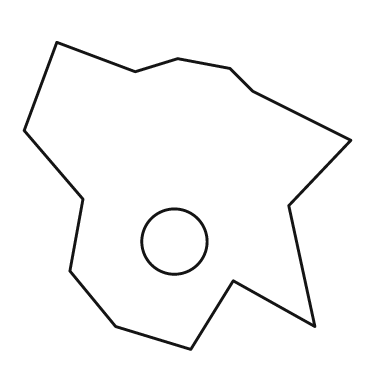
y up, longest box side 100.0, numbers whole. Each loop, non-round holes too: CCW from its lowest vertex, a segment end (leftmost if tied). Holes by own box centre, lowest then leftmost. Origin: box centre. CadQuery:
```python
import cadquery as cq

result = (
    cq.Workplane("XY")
    .moveTo(1.0, -47.0)
    .lineTo(14.0, -26.0)
    .lineTo(39.0, -40.0)
    .lineTo(31.0, -3.0)
    .lineTo(50.0, 17.0)
    .lineTo(20.0, 32.0)
    .lineTo(13.0, 39.0)
    .lineTo(-3.0, 42.0)
    .lineTo(-16.0, 38.0)
    .lineTo(-40.0, 47.0)
    .lineTo(-50.0, 20.0)
    .lineTo(-32.0, -1.0)
    .lineTo(-36.0, -23.0)
    .lineTo(-22.0, -40.0)
    .close()
    .moveTo(-4.0, -14.0)
    .circle(10.0)
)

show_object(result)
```